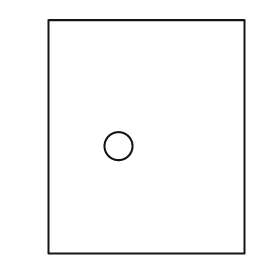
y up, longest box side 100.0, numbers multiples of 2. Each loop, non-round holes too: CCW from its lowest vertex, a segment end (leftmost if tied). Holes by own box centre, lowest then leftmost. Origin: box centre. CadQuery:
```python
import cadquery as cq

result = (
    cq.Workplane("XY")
    .moveTo(-42.0, -50.0)
    .lineTo(42.0, -50.0)
    .lineTo(42.0, 50.0)
    .lineTo(-42.0, 50.0)
    .close()
    .moveTo(-12.0, -4.0)
    .circle(6.0)
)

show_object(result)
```